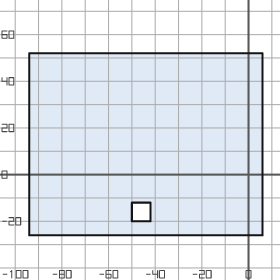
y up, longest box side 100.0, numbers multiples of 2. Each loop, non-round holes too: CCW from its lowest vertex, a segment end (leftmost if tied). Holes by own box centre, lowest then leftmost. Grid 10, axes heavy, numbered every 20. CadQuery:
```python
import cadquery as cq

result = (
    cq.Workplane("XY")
    .moveTo(-94.0, -26.0)
    .lineTo(6.0, -26.0)
    .lineTo(6.0, 52.0)
    .lineTo(-94.0, 52.0)
    .close()
    .moveTo(-50.0, -20.0)
    .lineTo(-42.0, -20.0)
    .lineTo(-42.0, -12.0)
    .lineTo(-50.0, -12.0)
    .close()
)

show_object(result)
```